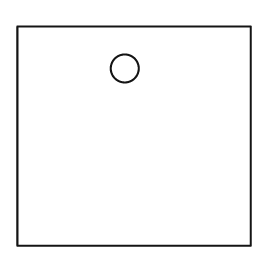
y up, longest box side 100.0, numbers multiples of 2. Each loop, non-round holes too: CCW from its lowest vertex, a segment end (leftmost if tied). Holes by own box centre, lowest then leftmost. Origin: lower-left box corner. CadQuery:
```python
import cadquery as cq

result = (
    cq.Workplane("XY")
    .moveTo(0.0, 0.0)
    .lineTo(100.0, 0.0)
    .lineTo(100.0, 94.0)
    .lineTo(0.0, 94.0)
    .close()
    .moveTo(46.0, 76.0)
    .circle(6.0)
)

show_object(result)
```